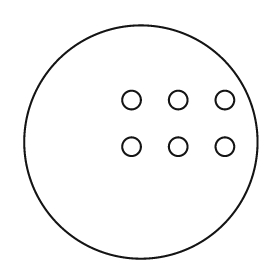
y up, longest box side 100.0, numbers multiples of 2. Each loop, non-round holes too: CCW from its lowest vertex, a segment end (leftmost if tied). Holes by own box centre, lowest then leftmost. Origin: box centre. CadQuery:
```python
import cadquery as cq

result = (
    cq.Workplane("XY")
    .moveTo(0.0, 0.0)
    .circle(50.0)
    .moveTo(-4.0, -2.0)
    .circle(4.0)
    .moveTo(16.0, -2.0)
    .circle(4.0)
    .moveTo(36.0, -2.0)
    .circle(4.0)
    .moveTo(-4.0, 18.0)
    .circle(4.0)
    .moveTo(16.0, 18.0)
    .circle(4.0)
    .moveTo(36.0, 18.0)
    .circle(4.0)
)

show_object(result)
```